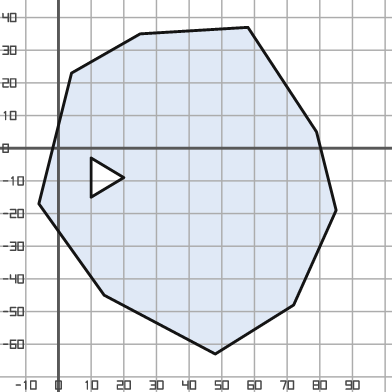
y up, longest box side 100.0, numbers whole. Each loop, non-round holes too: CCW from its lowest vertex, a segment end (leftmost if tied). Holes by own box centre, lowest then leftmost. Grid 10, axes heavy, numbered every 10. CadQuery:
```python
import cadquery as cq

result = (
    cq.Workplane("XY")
    .moveTo(48.0, -63.0)
    .lineTo(72.0, -48.0)
    .lineTo(85.0, -19.0)
    .lineTo(79.0, 5.0)
    .lineTo(58.0, 37.0)
    .lineTo(25.0, 35.0)
    .lineTo(4.0, 23.0)
    .lineTo(-6.0, -17.0)
    .lineTo(14.0, -45.0)
    .close()
    .moveTo(10.0, -15.0)
    .lineTo(20.0, -9.0)
    .lineTo(10.0, -3.0)
    .close()
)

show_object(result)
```